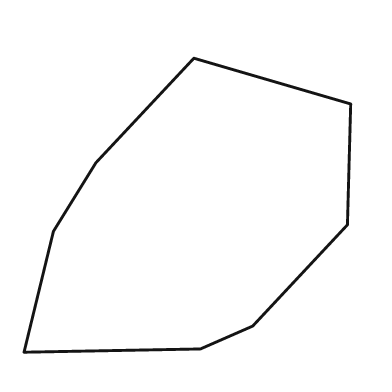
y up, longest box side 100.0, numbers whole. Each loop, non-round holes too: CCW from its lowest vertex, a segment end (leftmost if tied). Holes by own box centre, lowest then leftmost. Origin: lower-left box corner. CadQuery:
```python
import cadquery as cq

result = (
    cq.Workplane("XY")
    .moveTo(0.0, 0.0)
    .lineTo(54.0, 1.0)
    .lineTo(70.0, 8.0)
    .lineTo(99.0, 39.0)
    .lineTo(100.0, 76.0)
    .lineTo(52.0, 90.0)
    .lineTo(22.0, 58.0)
    .lineTo(9.0, 37.0)
    .close()
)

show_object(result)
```